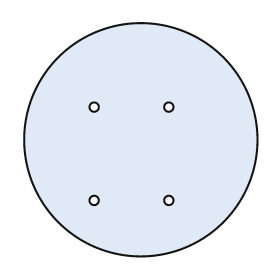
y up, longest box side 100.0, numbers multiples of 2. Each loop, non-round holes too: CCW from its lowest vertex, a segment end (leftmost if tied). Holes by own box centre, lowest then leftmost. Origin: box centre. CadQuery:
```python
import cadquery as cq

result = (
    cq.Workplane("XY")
    .moveTo(0.0, 0.0)
    .circle(50.0)
    .moveTo(-20.0, -26.0)
    .circle(2.0)
    .moveTo(12.0, -26.0)
    .circle(2.0)
    .moveTo(-20.0, 14.0)
    .circle(2.0)
    .moveTo(12.0, 14.0)
    .circle(2.0)
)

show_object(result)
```